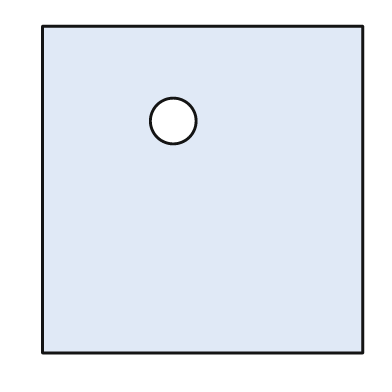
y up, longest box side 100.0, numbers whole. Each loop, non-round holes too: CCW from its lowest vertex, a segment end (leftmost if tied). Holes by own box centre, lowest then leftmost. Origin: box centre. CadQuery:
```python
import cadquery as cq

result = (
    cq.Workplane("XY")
    .moveTo(-49.0, -50.0)
    .lineTo(49.0, -50.0)
    .lineTo(49.0, 50.0)
    .lineTo(-49.0, 50.0)
    .close()
    .moveTo(-9.0, 21.0)
    .circle(7.0)
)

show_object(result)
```